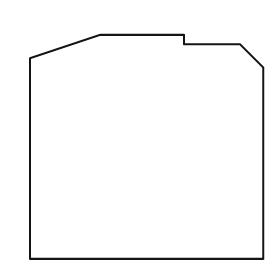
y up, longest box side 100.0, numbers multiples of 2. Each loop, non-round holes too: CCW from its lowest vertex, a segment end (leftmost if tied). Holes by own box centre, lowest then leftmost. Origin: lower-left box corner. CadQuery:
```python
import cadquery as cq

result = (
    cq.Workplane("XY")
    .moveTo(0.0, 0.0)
    .lineTo(100.0, 0.0)
    .lineTo(100.0, 82.0)
    .lineTo(90.0, 92.0)
    .lineTo(66.0, 92.0)
    .lineTo(66.0, 96.0)
    .lineTo(30.0, 96.0)
    .lineTo(0.0, 86.0)
    .close()
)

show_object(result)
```